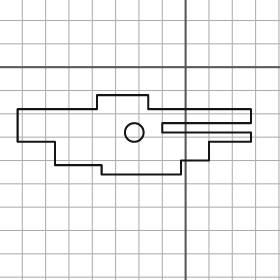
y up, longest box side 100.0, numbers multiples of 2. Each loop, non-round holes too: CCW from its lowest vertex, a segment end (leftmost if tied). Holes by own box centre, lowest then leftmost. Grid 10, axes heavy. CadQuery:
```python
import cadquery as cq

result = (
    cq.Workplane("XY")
    .moveTo(-36.0, -46.0)
    .lineTo(-2.0, -46.0)
    .lineTo(-2.0, -40.0)
    .lineTo(10.0, -40.0)
    .lineTo(10.0, -32.0)
    .lineTo(28.0, -32.0)
    .lineTo(28.0, -28.0)
    .lineTo(-10.0, -28.0)
    .lineTo(-10.0, -24.0)
    .lineTo(28.0, -24.0)
    .lineTo(28.0, -18.0)
    .lineTo(-16.0, -18.0)
    .lineTo(-16.0, -12.0)
    .lineTo(-38.0, -12.0)
    .lineTo(-38.0, -18.0)
    .lineTo(-72.0, -18.0)
    .lineTo(-72.0, -32.0)
    .lineTo(-56.0, -32.0)
    .lineTo(-56.0, -42.0)
    .lineTo(-36.0, -42.0)
    .close()
    .moveTo(-22.0, -28.0)
    .circle(4.0)
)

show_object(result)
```